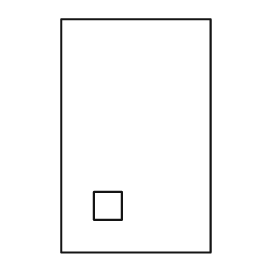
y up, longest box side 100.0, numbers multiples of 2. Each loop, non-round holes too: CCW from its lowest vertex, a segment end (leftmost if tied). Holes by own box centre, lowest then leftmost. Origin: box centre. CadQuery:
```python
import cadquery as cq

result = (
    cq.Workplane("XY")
    .moveTo(-32.0, -50.0)
    .lineTo(32.0, -50.0)
    .lineTo(32.0, 50.0)
    .lineTo(-32.0, 50.0)
    .close()
    .moveTo(-18.0, -36.0)
    .lineTo(-6.0, -36.0)
    .lineTo(-6.0, -24.0)
    .lineTo(-18.0, -24.0)
    .close()
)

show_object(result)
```